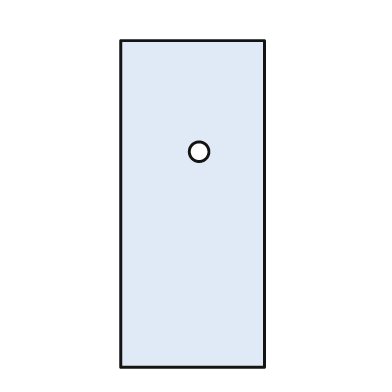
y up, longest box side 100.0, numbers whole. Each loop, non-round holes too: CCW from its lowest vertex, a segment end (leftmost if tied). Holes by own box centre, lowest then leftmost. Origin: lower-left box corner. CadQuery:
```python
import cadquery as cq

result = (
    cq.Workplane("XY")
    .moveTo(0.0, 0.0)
    .lineTo(44.0, 0.0)
    .lineTo(44.0, 100.0)
    .lineTo(0.0, 100.0)
    .close()
    .moveTo(24.0, 66.0)
    .circle(3.0)
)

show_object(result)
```